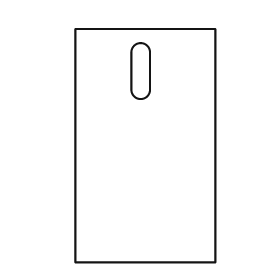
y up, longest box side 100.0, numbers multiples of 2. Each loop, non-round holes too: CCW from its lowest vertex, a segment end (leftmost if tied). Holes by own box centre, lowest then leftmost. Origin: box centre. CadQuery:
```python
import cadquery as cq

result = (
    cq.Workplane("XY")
    .moveTo(-30.0, -50.0)
    .lineTo(30.0, -50.0)
    .lineTo(30.0, 50.0)
    .lineTo(-30.0, 50.0)
    .close()
    .moveTo(-6.0, 24.0)
    .threePointArc((-2.0, 20.0), (2.0, 24.0))
    .lineTo(2.0, 40.0)
    .threePointArc((-2.0, 44.0), (-6.0, 40.0))
    .close()
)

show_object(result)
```